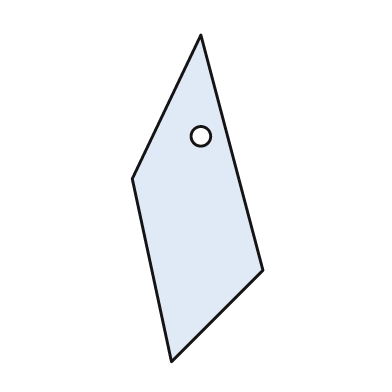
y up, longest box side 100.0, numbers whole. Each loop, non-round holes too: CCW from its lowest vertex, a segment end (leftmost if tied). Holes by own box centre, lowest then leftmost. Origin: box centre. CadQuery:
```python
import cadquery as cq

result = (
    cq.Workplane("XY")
    .moveTo(-8.0, -50.0)
    .lineTo(20.0, -22.0)
    .lineTo(1.0, 50.0)
    .lineTo(-20.0, 6.0)
    .close()
    .moveTo(1.0, 19.0)
    .circle(3.0)
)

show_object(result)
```